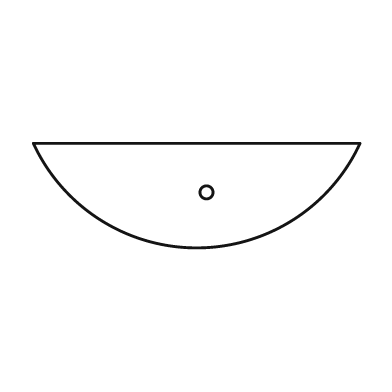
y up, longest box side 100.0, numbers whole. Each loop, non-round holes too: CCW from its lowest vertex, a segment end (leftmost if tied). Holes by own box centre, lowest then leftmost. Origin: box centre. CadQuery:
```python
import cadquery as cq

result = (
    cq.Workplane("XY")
    .moveTo(-50.0, 16.0)
    .threePointArc((0.0, -16.0), (50.0, 16.0))
    .close()
    .moveTo(3.0, 1.0)
    .circle(2.0)
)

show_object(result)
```